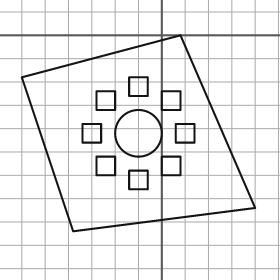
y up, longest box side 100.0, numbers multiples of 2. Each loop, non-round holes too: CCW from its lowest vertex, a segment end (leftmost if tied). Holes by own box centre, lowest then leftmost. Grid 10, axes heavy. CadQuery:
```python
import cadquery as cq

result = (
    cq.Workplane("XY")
    .moveTo(-38.0, -84.0)
    .lineTo(40.0, -74.0)
    .lineTo(8.0, 0.0)
    .lineTo(-60.0, -18.0)
    .close()
    .moveTo(-14.0, -66.0)
    .lineTo(-6.0, -66.0)
    .lineTo(-6.0, -58.0)
    .lineTo(-14.0, -58.0)
    .close()
    .moveTo(-28.0, -60.0)
    .lineTo(-20.0, -60.0)
    .lineTo(-20.0, -52.0)
    .lineTo(-28.0, -52.0)
    .close()
    .moveTo(0.0, -60.0)
    .lineTo(8.0, -60.0)
    .lineTo(8.0, -52.0)
    .lineTo(0.0, -52.0)
    .close()
    .moveTo(-34.0, -46.0)
    .lineTo(-26.0, -46.0)
    .lineTo(-26.0, -38.0)
    .lineTo(-34.0, -38.0)
    .close()
    .moveTo(-10.0, -42.0)
    .circle(10.0)
    .moveTo(6.0, -46.0)
    .lineTo(14.0, -46.0)
    .lineTo(14.0, -38.0)
    .lineTo(6.0, -38.0)
    .close()
    .moveTo(-28.0, -32.0)
    .lineTo(-20.0, -32.0)
    .lineTo(-20.0, -24.0)
    .lineTo(-28.0, -24.0)
    .close()
    .moveTo(0.0, -32.0)
    .lineTo(8.0, -32.0)
    .lineTo(8.0, -24.0)
    .lineTo(0.0, -24.0)
    .close()
    .moveTo(-14.0, -26.0)
    .lineTo(-6.0, -26.0)
    .lineTo(-6.0, -18.0)
    .lineTo(-14.0, -18.0)
    .close()
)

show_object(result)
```